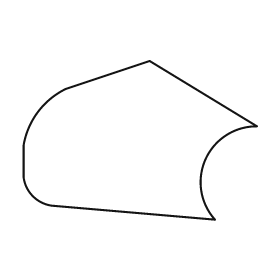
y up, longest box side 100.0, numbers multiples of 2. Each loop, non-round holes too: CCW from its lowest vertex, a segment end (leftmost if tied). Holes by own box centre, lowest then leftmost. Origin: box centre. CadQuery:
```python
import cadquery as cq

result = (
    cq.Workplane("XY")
    .moveTo(32.0, -34.0)
    .threePointArc((28.0, -8.0), (50.0, 6.0))
    .lineTo(4.0, 34.0)
    .lineTo(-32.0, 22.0)
    .threePointArc((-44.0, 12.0), (-50.0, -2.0))
    .lineTo(-50.0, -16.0)
    .threePointArc((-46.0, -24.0), (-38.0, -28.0))
    .close()
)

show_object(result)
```